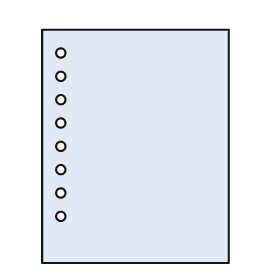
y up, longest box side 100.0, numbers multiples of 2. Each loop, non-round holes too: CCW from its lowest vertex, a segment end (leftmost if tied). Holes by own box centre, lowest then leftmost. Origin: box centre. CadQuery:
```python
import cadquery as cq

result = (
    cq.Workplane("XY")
    .moveTo(-40.0, -50.0)
    .lineTo(40.0, -50.0)
    .lineTo(40.0, 50.0)
    .lineTo(-40.0, 50.0)
    .close()
    .moveTo(-32.0, -30.0)
    .circle(2.0)
    .moveTo(-32.0, -20.0)
    .circle(2.0)
    .moveTo(-32.0, -10.0)
    .circle(2.0)
    .moveTo(-32.0, 0.0)
    .circle(2.0)
    .moveTo(-32.0, 10.0)
    .circle(2.0)
    .moveTo(-32.0, 20.0)
    .circle(2.0)
    .moveTo(-32.0, 30.0)
    .circle(2.0)
    .moveTo(-32.0, 40.0)
    .circle(2.0)
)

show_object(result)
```